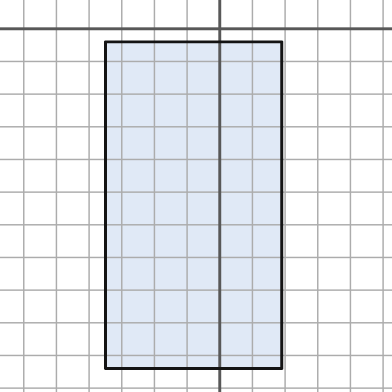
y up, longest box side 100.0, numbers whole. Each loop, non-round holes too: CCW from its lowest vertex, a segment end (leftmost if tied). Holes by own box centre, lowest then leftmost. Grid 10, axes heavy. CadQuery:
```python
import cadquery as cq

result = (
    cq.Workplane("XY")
    .moveTo(-35.0, -104.0)
    .lineTo(19.0, -104.0)
    .lineTo(19.0, -4.0)
    .lineTo(-35.0, -4.0)
    .close()
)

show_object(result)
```